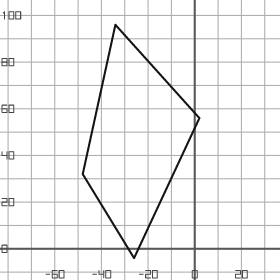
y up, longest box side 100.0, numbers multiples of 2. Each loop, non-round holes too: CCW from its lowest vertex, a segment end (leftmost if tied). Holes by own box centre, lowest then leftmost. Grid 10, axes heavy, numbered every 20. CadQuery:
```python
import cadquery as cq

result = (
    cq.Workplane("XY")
    .moveTo(-26.0, -4.0)
    .lineTo(2.0, 56.0)
    .lineTo(-34.0, 96.0)
    .lineTo(-48.0, 32.0)
    .close()
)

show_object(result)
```